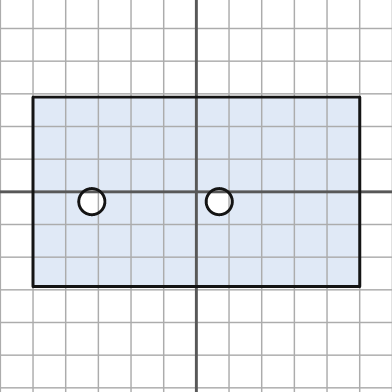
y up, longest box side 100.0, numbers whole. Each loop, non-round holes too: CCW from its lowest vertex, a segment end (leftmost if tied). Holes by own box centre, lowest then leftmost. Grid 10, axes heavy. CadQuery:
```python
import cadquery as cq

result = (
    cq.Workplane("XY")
    .moveTo(-50.0, -29.0)
    .lineTo(50.0, -29.0)
    .lineTo(50.0, 29.0)
    .lineTo(-50.0, 29.0)
    .close()
    .moveTo(-32.0, -3.0)
    .circle(4.0)
    .moveTo(7.0, -3.0)
    .circle(4.0)
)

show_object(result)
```